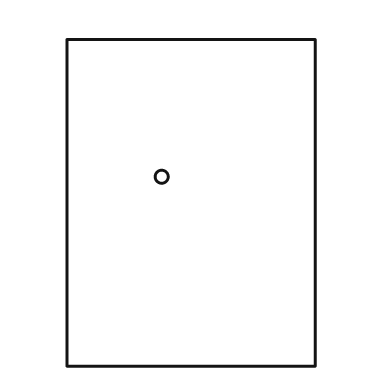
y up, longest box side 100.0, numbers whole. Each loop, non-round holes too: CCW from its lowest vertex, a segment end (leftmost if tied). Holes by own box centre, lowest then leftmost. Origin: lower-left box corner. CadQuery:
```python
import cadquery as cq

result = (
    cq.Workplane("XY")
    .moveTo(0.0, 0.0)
    .lineTo(76.0, 0.0)
    .lineTo(76.0, 100.0)
    .lineTo(0.0, 100.0)
    .close()
    .moveTo(29.0, 58.0)
    .circle(2.0)
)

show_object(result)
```